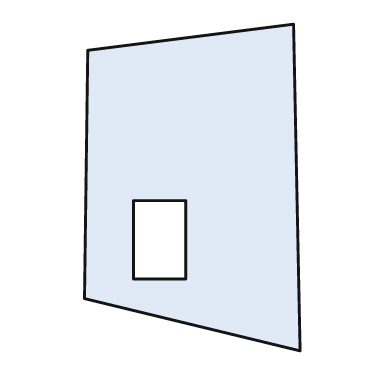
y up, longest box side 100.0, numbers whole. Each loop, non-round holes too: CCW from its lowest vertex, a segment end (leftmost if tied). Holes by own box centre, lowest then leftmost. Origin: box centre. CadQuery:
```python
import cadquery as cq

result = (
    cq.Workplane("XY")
    .moveTo(33.0, -50.0)
    .lineTo(31.0, 50.0)
    .lineTo(-32.0, 42.0)
    .lineTo(-33.0, -34.0)
    .close()
    .moveTo(-18.0, -28.0)
    .lineTo(-2.0, -28.0)
    .lineTo(-2.0, -4.0)
    .lineTo(-18.0, -4.0)
    .close()
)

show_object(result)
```